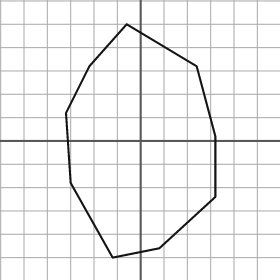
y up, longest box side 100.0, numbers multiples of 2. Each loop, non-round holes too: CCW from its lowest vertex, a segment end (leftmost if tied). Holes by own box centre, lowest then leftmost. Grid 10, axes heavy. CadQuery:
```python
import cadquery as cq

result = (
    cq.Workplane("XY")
    .moveTo(-12.0, -50.0)
    .lineTo(8.0, -46.0)
    .lineTo(32.0, -24.0)
    .lineTo(32.0, 2.0)
    .lineTo(24.0, 32.0)
    .lineTo(-6.0, 50.0)
    .lineTo(-22.0, 32.0)
    .lineTo(-32.0, 12.0)
    .lineTo(-30.0, -18.0)
    .close()
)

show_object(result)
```